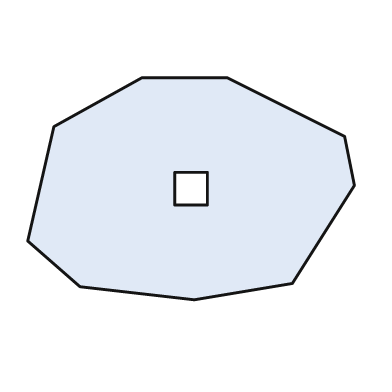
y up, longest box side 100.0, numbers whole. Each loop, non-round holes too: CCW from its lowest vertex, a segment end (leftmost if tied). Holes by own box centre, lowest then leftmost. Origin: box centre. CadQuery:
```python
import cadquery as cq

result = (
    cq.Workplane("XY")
    .moveTo(1.0, -34.0)
    .lineTo(31.0, -29.0)
    .lineTo(50.0, 1.0)
    .lineTo(47.0, 16.0)
    .lineTo(11.0, 34.0)
    .lineTo(-15.0, 34.0)
    .lineTo(-42.0, 19.0)
    .lineTo(-50.0, -16.0)
    .lineTo(-34.0, -30.0)
    .close()
    .moveTo(-5.0, -5.0)
    .lineTo(5.0, -5.0)
    .lineTo(5.0, 5.0)
    .lineTo(-5.0, 5.0)
    .close()
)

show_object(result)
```